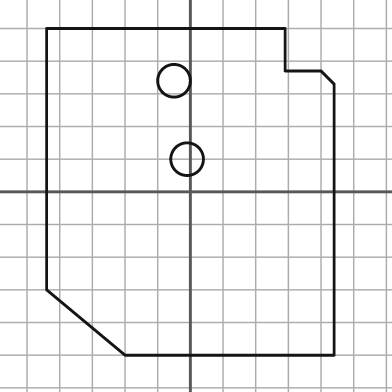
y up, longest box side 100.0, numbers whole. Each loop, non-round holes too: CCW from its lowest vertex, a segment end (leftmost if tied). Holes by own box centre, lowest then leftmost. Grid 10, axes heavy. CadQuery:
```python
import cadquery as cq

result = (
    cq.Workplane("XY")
    .moveTo(-20.0, -50.0)
    .lineTo(44.0, -50.0)
    .lineTo(44.0, 33.0)
    .lineTo(40.0, 37.0)
    .lineTo(29.0, 37.0)
    .lineTo(29.0, 50.0)
    .lineTo(-44.0, 50.0)
    .lineTo(-44.0, -30.0)
    .close()
    .moveTo(-1.0, 10.0)
    .circle(5.0)
    .moveTo(-5.0, 34.0)
    .circle(5.0)
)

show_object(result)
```